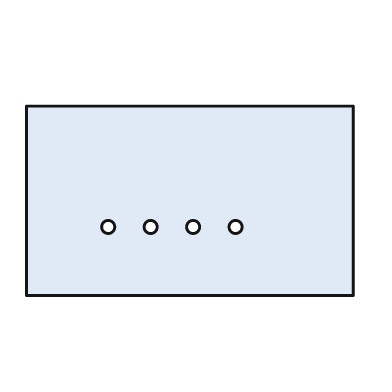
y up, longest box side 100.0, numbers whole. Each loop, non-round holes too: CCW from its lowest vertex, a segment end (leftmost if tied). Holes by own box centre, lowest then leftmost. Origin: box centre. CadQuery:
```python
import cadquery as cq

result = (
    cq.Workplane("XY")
    .moveTo(-50.0, -29.0)
    .lineTo(50.0, -29.0)
    .lineTo(50.0, 29.0)
    .lineTo(-50.0, 29.0)
    .close()
    .moveTo(-25.0, -8.0)
    .circle(2.0)
    .moveTo(-12.0, -8.0)
    .circle(2.0)
    .moveTo(1.0, -8.0)
    .circle(2.0)
    .moveTo(14.0, -8.0)
    .circle(2.0)
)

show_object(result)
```